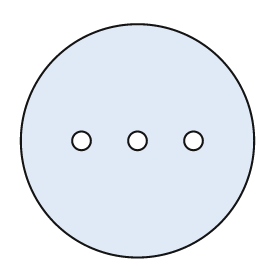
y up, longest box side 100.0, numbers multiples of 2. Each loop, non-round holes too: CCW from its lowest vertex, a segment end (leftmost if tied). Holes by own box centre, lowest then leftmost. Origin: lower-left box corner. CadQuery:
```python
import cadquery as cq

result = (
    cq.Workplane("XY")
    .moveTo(50.0, 50.0)
    .circle(50.0)
    .moveTo(26.0, 50.0)
    .circle(4.0)
    .moveTo(50.0, 50.0)
    .circle(4.0)
    .moveTo(74.0, 50.0)
    .circle(4.0)
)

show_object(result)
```